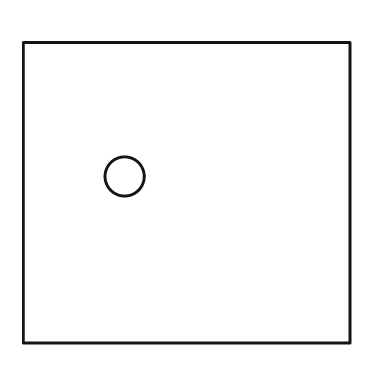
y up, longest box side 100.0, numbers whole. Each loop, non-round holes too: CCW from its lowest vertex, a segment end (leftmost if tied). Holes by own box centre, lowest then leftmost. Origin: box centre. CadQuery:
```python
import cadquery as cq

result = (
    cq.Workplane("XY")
    .moveTo(-50.0, -46.0)
    .lineTo(50.0, -46.0)
    .lineTo(50.0, 46.0)
    .lineTo(-50.0, 46.0)
    .close()
    .moveTo(-19.0, 5.0)
    .circle(6.0)
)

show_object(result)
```